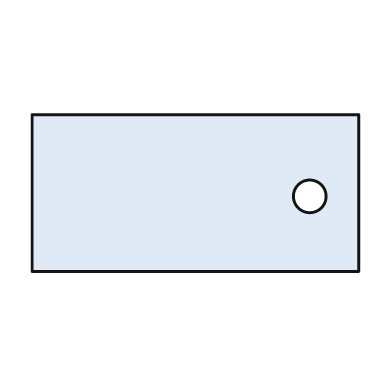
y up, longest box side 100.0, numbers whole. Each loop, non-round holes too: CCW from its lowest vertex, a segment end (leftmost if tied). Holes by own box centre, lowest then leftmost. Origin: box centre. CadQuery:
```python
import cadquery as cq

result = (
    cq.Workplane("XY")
    .moveTo(-50.0, -24.0)
    .lineTo(50.0, -24.0)
    .lineTo(50.0, 24.0)
    .lineTo(-50.0, 24.0)
    .close()
    .moveTo(35.0, -1.0)
    .circle(5.0)
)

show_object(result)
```